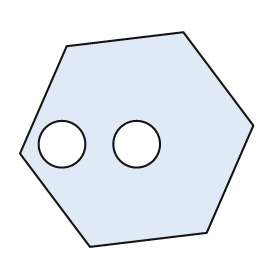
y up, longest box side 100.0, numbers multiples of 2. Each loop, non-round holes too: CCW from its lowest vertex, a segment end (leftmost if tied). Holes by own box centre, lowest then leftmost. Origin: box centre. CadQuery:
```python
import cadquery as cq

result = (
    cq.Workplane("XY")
    .moveTo(-20.0, -46.0)
    .lineTo(30.0, -40.0)
    .lineTo(50.0, 6.0)
    .lineTo(20.0, 46.0)
    .lineTo(-30.0, 40.0)
    .lineTo(-50.0, -6.0)
    .close()
    .moveTo(-32.0, -2.0)
    .circle(10.0)
    .moveTo(0.0, -2.0)
    .circle(10.0)
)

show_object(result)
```